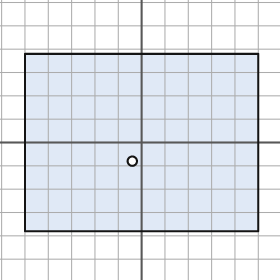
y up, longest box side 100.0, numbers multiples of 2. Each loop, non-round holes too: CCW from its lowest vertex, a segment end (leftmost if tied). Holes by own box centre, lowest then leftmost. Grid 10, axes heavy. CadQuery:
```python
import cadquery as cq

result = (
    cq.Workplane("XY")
    .moveTo(-50.0, -38.0)
    .lineTo(50.0, -38.0)
    .lineTo(50.0, 38.0)
    .lineTo(-50.0, 38.0)
    .close()
    .moveTo(-4.0, -8.0)
    .circle(2.0)
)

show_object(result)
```